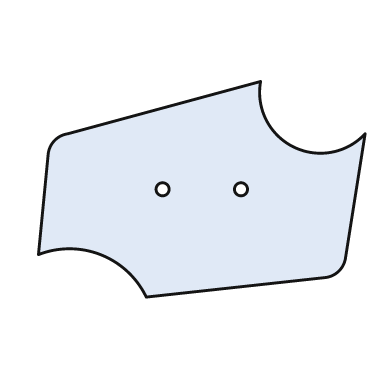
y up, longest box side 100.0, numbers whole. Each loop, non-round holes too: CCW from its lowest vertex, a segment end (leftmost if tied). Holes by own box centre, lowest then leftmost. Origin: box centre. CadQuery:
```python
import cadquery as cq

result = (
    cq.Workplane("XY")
    .moveTo(-17.0, -33.0)
    .lineTo(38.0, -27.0)
    .threePointArc((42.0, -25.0), (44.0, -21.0))
    .lineTo(50.0, 17.0)
    .threePointArc((28.0, 13.0), (18.0, 33.0))
    .lineTo(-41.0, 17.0)
    .threePointArc((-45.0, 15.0), (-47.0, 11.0))
    .lineTo(-50.0, -20.0)
    .threePointArc((-31.0, -20.0), (-17.0, -33.0))
    .close()
    .moveTo(-12.0, 0.0)
    .circle(2.0)
    .moveTo(12.0, 0.0)
    .circle(2.0)
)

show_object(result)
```